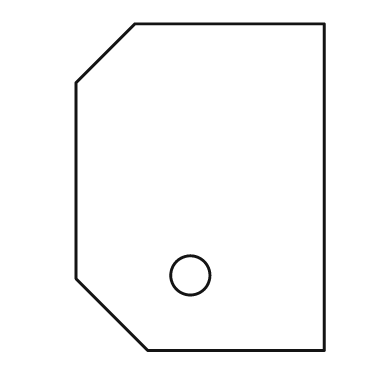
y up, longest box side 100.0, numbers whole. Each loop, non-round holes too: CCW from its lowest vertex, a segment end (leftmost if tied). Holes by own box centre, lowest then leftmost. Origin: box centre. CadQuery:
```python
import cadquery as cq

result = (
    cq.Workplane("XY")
    .moveTo(-16.0, -50.0)
    .lineTo(38.0, -50.0)
    .lineTo(38.0, 50.0)
    .lineTo(-20.0, 50.0)
    .lineTo(-38.0, 32.0)
    .lineTo(-38.0, -28.0)
    .close()
    .moveTo(-3.0, -27.0)
    .circle(6.0)
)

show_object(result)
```